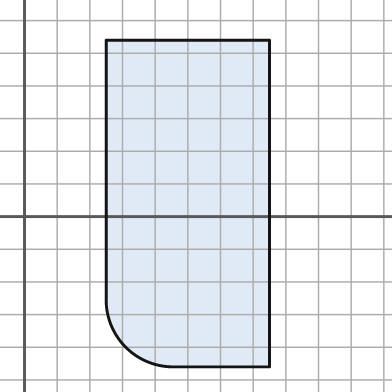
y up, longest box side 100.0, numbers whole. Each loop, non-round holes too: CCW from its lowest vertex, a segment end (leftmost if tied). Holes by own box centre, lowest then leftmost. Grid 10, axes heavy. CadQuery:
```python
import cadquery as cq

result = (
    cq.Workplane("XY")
    .moveTo(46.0, -46.0)
    .lineTo(75.0, -46.0)
    .lineTo(75.0, 54.0)
    .lineTo(25.0, 54.0)
    .lineTo(25.0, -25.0)
    .threePointArc((31.0, -40.0), (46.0, -46.0))
    .close()
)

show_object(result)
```